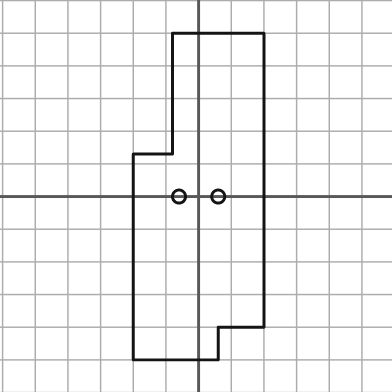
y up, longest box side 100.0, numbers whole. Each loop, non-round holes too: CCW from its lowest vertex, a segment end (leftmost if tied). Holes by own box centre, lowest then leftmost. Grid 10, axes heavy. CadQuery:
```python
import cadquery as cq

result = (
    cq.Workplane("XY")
    .moveTo(-20.0, -50.0)
    .lineTo(6.0, -50.0)
    .lineTo(6.0, -40.0)
    .lineTo(20.0, -40.0)
    .lineTo(20.0, 50.0)
    .lineTo(-8.0, 50.0)
    .lineTo(-8.0, 13.0)
    .lineTo(-20.0, 13.0)
    .close()
    .moveTo(-6.0, 0.0)
    .circle(2.0)
    .moveTo(6.0, 0.0)
    .circle(2.0)
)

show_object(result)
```